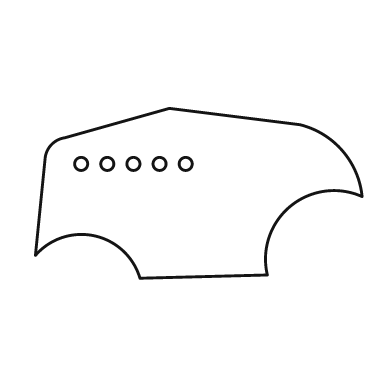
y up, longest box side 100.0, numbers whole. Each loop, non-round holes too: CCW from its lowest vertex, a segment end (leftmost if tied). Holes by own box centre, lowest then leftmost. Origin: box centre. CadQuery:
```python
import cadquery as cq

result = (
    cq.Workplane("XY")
    .moveTo(-18.0, -26.0)
    .lineTo(21.0, -25.0)
    .threePointArc((28.0, -4.0), (50.0, -1.0))
    .threePointArc((44.0, 13.0), (31.0, 21.0))
    .lineTo(-9.0, 26.0)
    .lineTo(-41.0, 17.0)
    .threePointArc((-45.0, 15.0), (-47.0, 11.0))
    .lineTo(-50.0, -19.0)
    .threePointArc((-32.0, -13.0), (-18.0, -26.0))
    .close()
    .moveTo(-36.0, 9.0)
    .circle(2.0)
    .moveTo(-28.0, 9.0)
    .circle(2.0)
    .moveTo(-20.0, 9.0)
    .circle(2.0)
    .moveTo(-12.0, 9.0)
    .circle(2.0)
    .moveTo(-4.0, 9.0)
    .circle(2.0)
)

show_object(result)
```